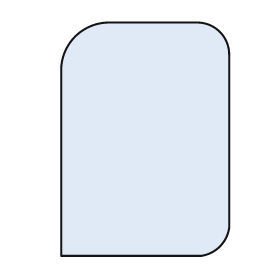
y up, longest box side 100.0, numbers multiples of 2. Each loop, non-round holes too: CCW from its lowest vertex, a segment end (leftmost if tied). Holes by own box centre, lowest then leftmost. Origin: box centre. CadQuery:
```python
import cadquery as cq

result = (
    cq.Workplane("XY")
    .moveTo(-36.0, -50.0)
    .lineTo(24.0, -50.0)
    .threePointArc((32.0, -46.0), (36.0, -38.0))
    .lineTo(36.0, 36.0)
    .threePointArc((32.0, 46.0), (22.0, 50.0))
    .lineTo(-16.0, 50.0)
    .threePointArc((-30.0, 44.0), (-36.0, 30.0))
    .close()
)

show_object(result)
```